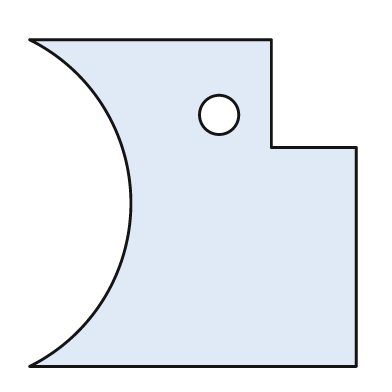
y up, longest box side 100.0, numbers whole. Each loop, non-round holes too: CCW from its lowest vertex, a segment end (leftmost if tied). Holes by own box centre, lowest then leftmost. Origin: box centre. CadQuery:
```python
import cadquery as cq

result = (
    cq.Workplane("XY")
    .moveTo(-50.0, -50.0)
    .lineTo(50.0, -50.0)
    .lineTo(50.0, 17.0)
    .lineTo(24.0, 17.0)
    .lineTo(24.0, 50.0)
    .lineTo(-50.0, 50.0)
    .threePointArc((-19.0, 0.0), (-50.0, -50.0))
    .close()
    .moveTo(8.0, 27.0)
    .circle(6.0)
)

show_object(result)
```